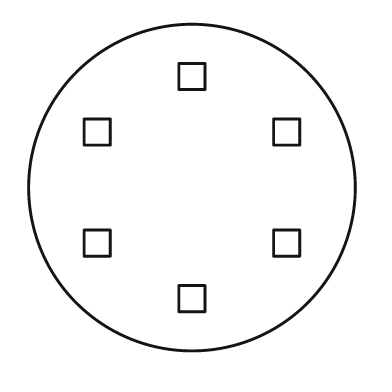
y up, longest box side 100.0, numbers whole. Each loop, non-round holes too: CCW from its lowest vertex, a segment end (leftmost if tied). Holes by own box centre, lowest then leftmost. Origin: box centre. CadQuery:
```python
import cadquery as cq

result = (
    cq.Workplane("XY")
    .moveTo(0.0, 0.0)
    .circle(50.0)
    .moveTo(-4.0, -38.0)
    .lineTo(4.0, -38.0)
    .lineTo(4.0, -30.0)
    .lineTo(-4.0, -30.0)
    .close()
    .moveTo(-33.0, -21.0)
    .lineTo(-25.0, -21.0)
    .lineTo(-25.0, -13.0)
    .lineTo(-33.0, -13.0)
    .close()
    .moveTo(25.0, -21.0)
    .lineTo(33.0, -21.0)
    .lineTo(33.0, -13.0)
    .lineTo(25.0, -13.0)
    .close()
    .moveTo(-33.0, 13.0)
    .lineTo(-25.0, 13.0)
    .lineTo(-25.0, 21.0)
    .lineTo(-33.0, 21.0)
    .close()
    .moveTo(25.0, 13.0)
    .lineTo(33.0, 13.0)
    .lineTo(33.0, 21.0)
    .lineTo(25.0, 21.0)
    .close()
    .moveTo(-4.0, 30.0)
    .lineTo(4.0, 30.0)
    .lineTo(4.0, 38.0)
    .lineTo(-4.0, 38.0)
    .close()
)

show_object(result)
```